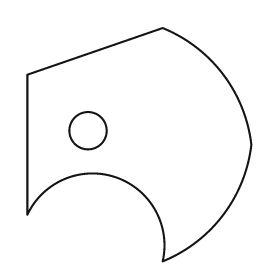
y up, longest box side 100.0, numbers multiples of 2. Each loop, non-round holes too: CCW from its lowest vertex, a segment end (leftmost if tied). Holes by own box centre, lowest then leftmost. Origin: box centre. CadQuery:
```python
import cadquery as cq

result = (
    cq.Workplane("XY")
    .moveTo(10.0, -50.0)
    .threePointArc((36.0, -30.0), (48.0, 0.0))
    .threePointArc((36.0, 30.0), (10.0, 50.0))
    .lineTo(-48.0, 30.0)
    .lineTo(-48.0, -30.0)
    .threePointArc((-10.0, -14.0), (10.0, -50.0))
    .close()
    .moveTo(-22.0, 6.0)
    .circle(8.0)
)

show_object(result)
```